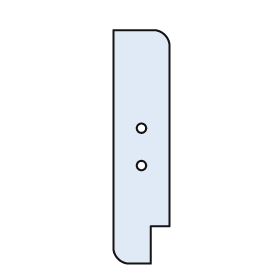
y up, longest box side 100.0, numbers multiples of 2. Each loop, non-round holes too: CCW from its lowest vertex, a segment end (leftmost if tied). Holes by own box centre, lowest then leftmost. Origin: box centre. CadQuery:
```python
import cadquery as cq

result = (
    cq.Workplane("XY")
    .moveTo(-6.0, -50.0)
    .lineTo(4.0, -50.0)
    .lineTo(4.0, -34.0)
    .lineTo(12.0, -34.0)
    .lineTo(12.0, 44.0)
    .threePointArc((10.0, 48.0), (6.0, 50.0))
    .lineTo(-12.0, 50.0)
    .lineTo(-12.0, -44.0)
    .threePointArc((-10.0, -48.0), (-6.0, -50.0))
    .close()
    .moveTo(0.0, -8.0)
    .circle(2.0)
    .moveTo(0.0, 8.0)
    .circle(2.0)
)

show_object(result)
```